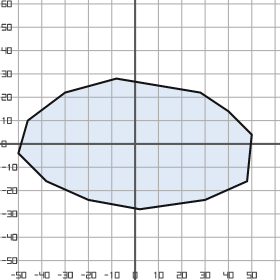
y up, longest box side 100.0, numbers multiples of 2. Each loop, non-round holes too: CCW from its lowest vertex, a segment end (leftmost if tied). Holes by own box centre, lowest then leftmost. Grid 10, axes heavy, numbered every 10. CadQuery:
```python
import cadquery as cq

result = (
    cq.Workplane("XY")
    .moveTo(2.0, -28.0)
    .lineTo(30.0, -24.0)
    .lineTo(48.0, -16.0)
    .lineTo(50.0, 4.0)
    .lineTo(40.0, 14.0)
    .lineTo(28.0, 22.0)
    .lineTo(-8.0, 28.0)
    .lineTo(-30.0, 22.0)
    .lineTo(-46.0, 10.0)
    .lineTo(-50.0, -4.0)
    .lineTo(-38.0, -16.0)
    .lineTo(-20.0, -24.0)
    .close()
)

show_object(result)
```